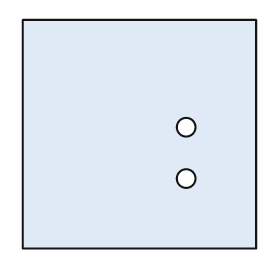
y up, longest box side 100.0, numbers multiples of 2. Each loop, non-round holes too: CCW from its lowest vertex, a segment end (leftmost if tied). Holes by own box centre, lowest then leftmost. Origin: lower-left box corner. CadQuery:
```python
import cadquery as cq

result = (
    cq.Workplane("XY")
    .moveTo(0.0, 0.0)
    .lineTo(100.0, 0.0)
    .lineTo(100.0, 98.0)
    .lineTo(0.0, 98.0)
    .close()
    .moveTo(70.0, 30.0)
    .circle(4.0)
    .moveTo(70.0, 52.0)
    .circle(4.0)
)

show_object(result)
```